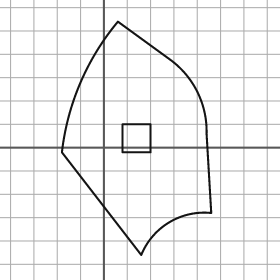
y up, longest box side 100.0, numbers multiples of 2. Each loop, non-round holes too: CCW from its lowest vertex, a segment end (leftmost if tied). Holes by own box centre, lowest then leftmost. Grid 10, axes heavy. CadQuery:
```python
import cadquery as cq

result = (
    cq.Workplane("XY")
    .moveTo(16.0, -46.0)
    .threePointArc((28.0, -32.0), (46.0, -28.0))
    .lineTo(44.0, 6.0)
    .threePointArc((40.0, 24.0), (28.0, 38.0))
    .lineTo(6.0, 54.0)
    .threePointArc((-10.0, 28.0), (-18.0, -2.0))
    .close()
    .moveTo(8.0, -2.0)
    .lineTo(20.0, -2.0)
    .lineTo(20.0, 10.0)
    .lineTo(8.0, 10.0)
    .close()
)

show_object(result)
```